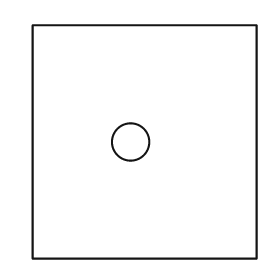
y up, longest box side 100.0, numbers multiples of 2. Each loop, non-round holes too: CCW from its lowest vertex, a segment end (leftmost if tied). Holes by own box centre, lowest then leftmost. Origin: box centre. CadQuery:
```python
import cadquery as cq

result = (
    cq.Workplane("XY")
    .moveTo(-48.0, -50.0)
    .lineTo(48.0, -50.0)
    .lineTo(48.0, 50.0)
    .lineTo(-48.0, 50.0)
    .close()
    .moveTo(-6.0, 0.0)
    .circle(8.0)
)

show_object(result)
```